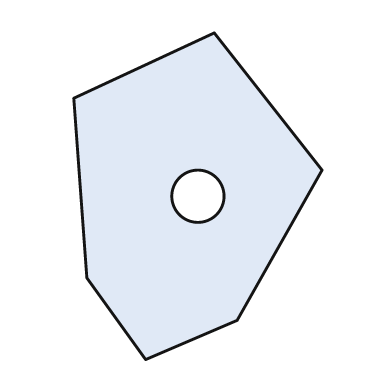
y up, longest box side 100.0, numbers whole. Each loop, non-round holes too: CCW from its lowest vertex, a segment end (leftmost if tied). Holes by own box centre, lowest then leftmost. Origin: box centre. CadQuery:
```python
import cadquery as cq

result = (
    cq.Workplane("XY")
    .moveTo(-16.0, -50.0)
    .lineTo(12.0, -38.0)
    .lineTo(38.0, 8.0)
    .lineTo(5.0, 50.0)
    .lineTo(-38.0, 30.0)
    .lineTo(-34.0, -25.0)
    .close()
    .moveTo(0.0, 0.0)
    .circle(8.0)
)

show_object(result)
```